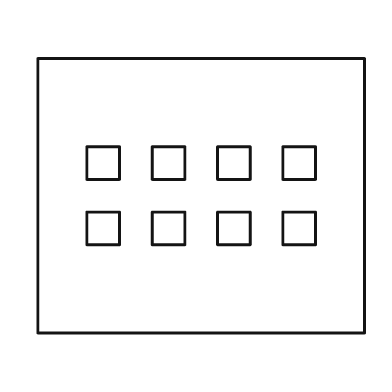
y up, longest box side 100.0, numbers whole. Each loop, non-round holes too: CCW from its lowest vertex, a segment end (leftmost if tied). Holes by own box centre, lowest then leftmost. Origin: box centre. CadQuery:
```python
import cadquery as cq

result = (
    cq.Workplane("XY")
    .moveTo(-50.0, -42.0)
    .lineTo(50.0, -42.0)
    .lineTo(50.0, 42.0)
    .lineTo(-50.0, 42.0)
    .close()
    .moveTo(-35.0, -15.0)
    .lineTo(-25.0, -15.0)
    .lineTo(-25.0, -5.0)
    .lineTo(-35.0, -5.0)
    .close()
    .moveTo(-15.0, -15.0)
    .lineTo(-5.0, -15.0)
    .lineTo(-5.0, -5.0)
    .lineTo(-15.0, -5.0)
    .close()
    .moveTo(5.0, -15.0)
    .lineTo(15.0, -15.0)
    .lineTo(15.0, -5.0)
    .lineTo(5.0, -5.0)
    .close()
    .moveTo(25.0, -15.0)
    .lineTo(35.0, -15.0)
    .lineTo(35.0, -5.0)
    .lineTo(25.0, -5.0)
    .close()
    .moveTo(-35.0, 5.0)
    .lineTo(-25.0, 5.0)
    .lineTo(-25.0, 15.0)
    .lineTo(-35.0, 15.0)
    .close()
    .moveTo(-15.0, 5.0)
    .lineTo(-5.0, 5.0)
    .lineTo(-5.0, 15.0)
    .lineTo(-15.0, 15.0)
    .close()
    .moveTo(5.0, 5.0)
    .lineTo(15.0, 5.0)
    .lineTo(15.0, 15.0)
    .lineTo(5.0, 15.0)
    .close()
    .moveTo(25.0, 5.0)
    .lineTo(35.0, 5.0)
    .lineTo(35.0, 15.0)
    .lineTo(25.0, 15.0)
    .close()
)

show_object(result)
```